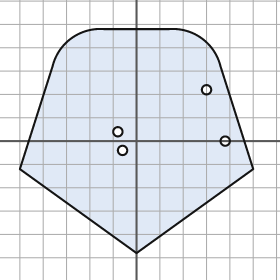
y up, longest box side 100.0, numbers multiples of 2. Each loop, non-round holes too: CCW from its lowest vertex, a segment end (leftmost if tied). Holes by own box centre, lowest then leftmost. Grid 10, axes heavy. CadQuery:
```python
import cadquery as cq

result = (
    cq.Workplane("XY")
    .moveTo(0.0, -48.0)
    .lineTo(50.0, -12.0)
    .lineTo(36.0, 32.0)
    .threePointArc((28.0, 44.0), (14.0, 48.0))
    .lineTo(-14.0, 48.0)
    .threePointArc((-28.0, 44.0), (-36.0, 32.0))
    .lineTo(-50.0, -12.0)
    .close()
    .moveTo(-6.0, -4.0)
    .circle(2.0)
    .moveTo(38.0, 0.0)
    .circle(2.0)
    .moveTo(-8.0, 4.0)
    .circle(2.0)
    .moveTo(30.0, 22.0)
    .circle(2.0)
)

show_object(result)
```